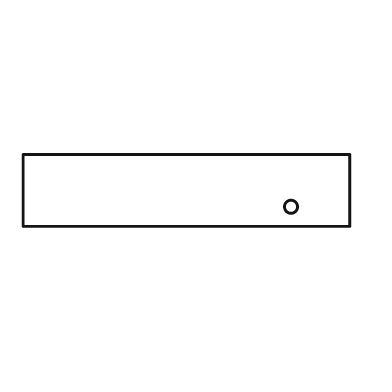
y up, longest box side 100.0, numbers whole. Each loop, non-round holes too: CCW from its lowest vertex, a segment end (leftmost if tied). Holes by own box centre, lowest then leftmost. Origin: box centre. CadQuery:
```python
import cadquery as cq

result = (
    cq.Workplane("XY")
    .moveTo(-50.0, -11.0)
    .lineTo(50.0, -11.0)
    .lineTo(50.0, 11.0)
    .lineTo(-50.0, 11.0)
    .close()
    .moveTo(32.0, -5.0)
    .circle(2.0)
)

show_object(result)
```